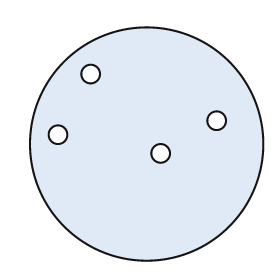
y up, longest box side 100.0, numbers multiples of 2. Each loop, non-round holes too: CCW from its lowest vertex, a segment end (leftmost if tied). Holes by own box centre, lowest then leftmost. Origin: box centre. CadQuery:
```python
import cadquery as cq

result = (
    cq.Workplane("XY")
    .moveTo(0.0, 0.0)
    .circle(50.0)
    .moveTo(6.0, -4.0)
    .circle(4.0)
    .moveTo(-38.0, 4.0)
    .circle(4.0)
    .moveTo(30.0, 10.0)
    .circle(4.0)
    .moveTo(-24.0, 30.0)
    .circle(4.0)
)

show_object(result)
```